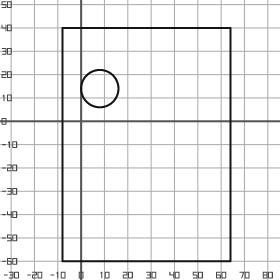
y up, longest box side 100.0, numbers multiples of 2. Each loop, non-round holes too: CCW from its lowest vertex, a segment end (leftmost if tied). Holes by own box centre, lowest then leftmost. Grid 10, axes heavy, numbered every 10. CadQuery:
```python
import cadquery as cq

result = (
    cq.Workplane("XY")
    .moveTo(-8.0, -60.0)
    .lineTo(64.0, -60.0)
    .lineTo(64.0, 40.0)
    .lineTo(-8.0, 40.0)
    .close()
    .moveTo(8.0, 14.0)
    .circle(8.0)
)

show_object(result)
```